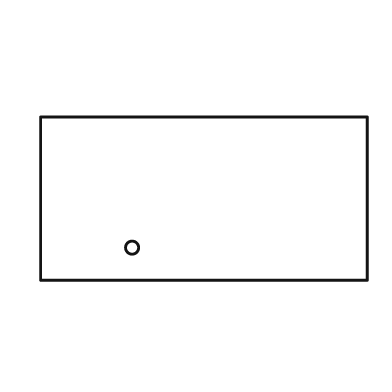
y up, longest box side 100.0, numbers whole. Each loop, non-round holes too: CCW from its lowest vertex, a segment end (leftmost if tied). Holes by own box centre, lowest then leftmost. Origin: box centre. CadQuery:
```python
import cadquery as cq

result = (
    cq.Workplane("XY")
    .moveTo(-50.0, -25.0)
    .lineTo(50.0, -25.0)
    .lineTo(50.0, 25.0)
    .lineTo(-50.0, 25.0)
    .close()
    .moveTo(-22.0, -15.0)
    .circle(2.0)
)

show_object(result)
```